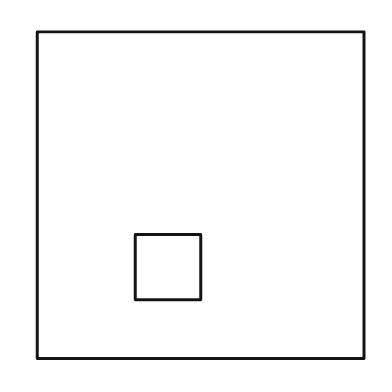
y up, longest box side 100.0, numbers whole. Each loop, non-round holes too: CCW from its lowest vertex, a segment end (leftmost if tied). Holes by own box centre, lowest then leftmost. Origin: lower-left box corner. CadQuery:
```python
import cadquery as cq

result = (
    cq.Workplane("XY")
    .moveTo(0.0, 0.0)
    .lineTo(100.0, 0.0)
    .lineTo(100.0, 100.0)
    .lineTo(0.0, 100.0)
    .close()
    .moveTo(30.0, 18.0)
    .lineTo(50.0, 18.0)
    .lineTo(50.0, 38.0)
    .lineTo(30.0, 38.0)
    .close()
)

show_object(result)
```